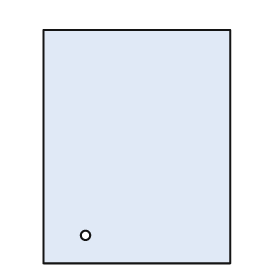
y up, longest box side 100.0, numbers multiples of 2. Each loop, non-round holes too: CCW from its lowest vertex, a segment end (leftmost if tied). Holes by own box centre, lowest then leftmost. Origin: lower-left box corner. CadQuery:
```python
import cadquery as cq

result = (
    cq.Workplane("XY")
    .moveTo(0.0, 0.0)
    .lineTo(80.0, 0.0)
    .lineTo(80.0, 100.0)
    .lineTo(0.0, 100.0)
    .close()
    .moveTo(18.0, 12.0)
    .circle(2.0)
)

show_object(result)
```